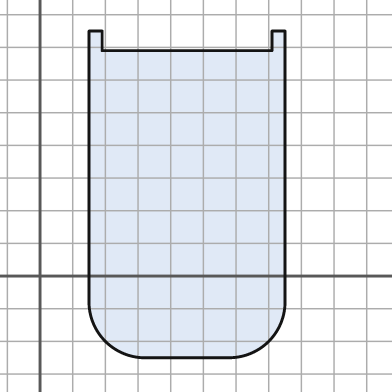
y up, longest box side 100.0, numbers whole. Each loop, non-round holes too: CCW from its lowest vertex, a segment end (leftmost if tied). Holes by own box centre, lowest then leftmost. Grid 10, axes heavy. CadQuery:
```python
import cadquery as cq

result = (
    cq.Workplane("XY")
    .moveTo(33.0, -25.0)
    .lineTo(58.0, -25.0)
    .threePointArc((70.0, -20.0), (75.0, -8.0))
    .lineTo(75.0, 75.0)
    .lineTo(71.0, 75.0)
    .lineTo(71.0, 69.0)
    .lineTo(19.0, 69.0)
    .lineTo(19.0, 75.0)
    .lineTo(15.0, 75.0)
    .lineTo(15.0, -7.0)
    .threePointArc((20.0, -20.0), (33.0, -25.0))
    .close()
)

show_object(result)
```